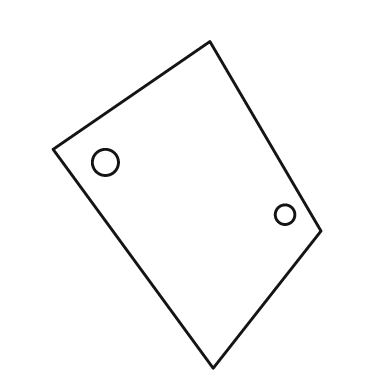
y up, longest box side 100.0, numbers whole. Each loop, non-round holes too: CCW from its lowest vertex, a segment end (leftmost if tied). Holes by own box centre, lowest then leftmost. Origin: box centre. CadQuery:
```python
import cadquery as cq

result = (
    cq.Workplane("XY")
    .moveTo(8.0, -50.0)
    .lineTo(41.0, -8.0)
    .lineTo(7.0, 50.0)
    .lineTo(-41.0, 17.0)
    .close()
    .moveTo(30.0, -3.0)
    .circle(3.0)
    .moveTo(-25.0, 13.0)
    .circle(4.0)
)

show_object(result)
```